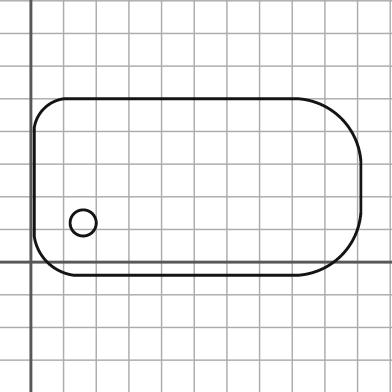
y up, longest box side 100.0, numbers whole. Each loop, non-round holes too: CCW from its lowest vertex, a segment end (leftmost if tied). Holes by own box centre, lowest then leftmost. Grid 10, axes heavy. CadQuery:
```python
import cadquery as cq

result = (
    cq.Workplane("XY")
    .moveTo(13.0, -4.0)
    .lineTo(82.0, -4.0)
    .threePointArc((95.0, 2.0), (101.0, 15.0))
    .lineTo(101.0, 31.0)
    .threePointArc((95.0, 44.0), (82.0, 50.0))
    .lineTo(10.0, 50.0)
    .threePointArc((4.0, 47.0), (1.0, 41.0))
    .lineTo(1.0, 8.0)
    .threePointArc((5.0, 0.0), (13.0, -4.0))
    .close()
    .moveTo(16.0, 12.0)
    .circle(4.0)
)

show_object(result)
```